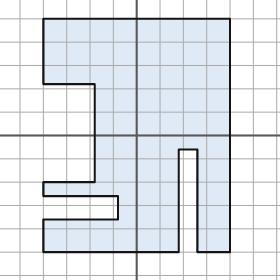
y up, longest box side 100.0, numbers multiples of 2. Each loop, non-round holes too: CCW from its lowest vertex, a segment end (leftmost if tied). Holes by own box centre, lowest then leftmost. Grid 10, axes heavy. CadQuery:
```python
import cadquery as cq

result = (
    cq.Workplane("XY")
    .moveTo(-40.0, -50.0)
    .lineTo(18.0, -50.0)
    .lineTo(18.0, -6.0)
    .lineTo(26.0, -6.0)
    .lineTo(26.0, -50.0)
    .lineTo(40.0, -50.0)
    .lineTo(40.0, 50.0)
    .lineTo(-40.0, 50.0)
    .lineTo(-40.0, 22.0)
    .lineTo(-18.0, 22.0)
    .lineTo(-18.0, -20.0)
    .lineTo(-40.0, -20.0)
    .lineTo(-40.0, -26.0)
    .lineTo(-8.0, -26.0)
    .lineTo(-8.0, -36.0)
    .lineTo(-40.0, -36.0)
    .close()
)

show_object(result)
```